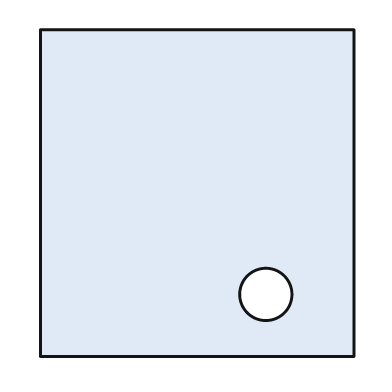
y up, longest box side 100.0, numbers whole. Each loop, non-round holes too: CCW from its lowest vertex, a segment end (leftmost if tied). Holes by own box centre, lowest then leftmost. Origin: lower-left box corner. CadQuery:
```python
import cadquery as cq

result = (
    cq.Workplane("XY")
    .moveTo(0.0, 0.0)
    .lineTo(96.0, 0.0)
    .lineTo(96.0, 100.0)
    .lineTo(0.0, 100.0)
    .close()
    .moveTo(69.0, 19.0)
    .circle(8.0)
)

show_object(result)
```